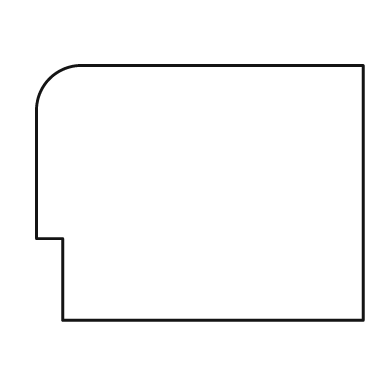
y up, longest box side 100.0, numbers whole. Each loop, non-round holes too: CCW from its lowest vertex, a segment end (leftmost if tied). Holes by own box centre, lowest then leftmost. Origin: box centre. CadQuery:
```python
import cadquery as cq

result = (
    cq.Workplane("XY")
    .moveTo(-42.0, -39.0)
    .lineTo(50.0, -39.0)
    .lineTo(50.0, 39.0)
    .lineTo(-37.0, 39.0)
    .threePointArc((-46.0, 35.0), (-50.0, 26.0))
    .lineTo(-50.0, -14.0)
    .lineTo(-42.0, -14.0)
    .close()
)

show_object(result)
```